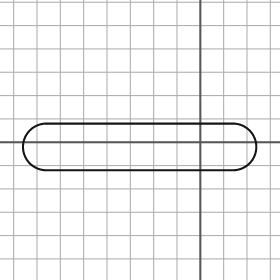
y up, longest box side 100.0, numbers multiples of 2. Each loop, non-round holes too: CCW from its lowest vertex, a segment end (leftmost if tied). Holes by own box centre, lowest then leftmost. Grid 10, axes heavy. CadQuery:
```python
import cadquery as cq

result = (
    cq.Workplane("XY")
    .moveTo(-66.0, -12.0)
    .lineTo(14.0, -12.0)
    .threePointArc((24.0, -2.0), (14.0, 8.0))
    .lineTo(-66.0, 8.0)
    .threePointArc((-76.0, -2.0), (-66.0, -12.0))
    .close()
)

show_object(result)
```